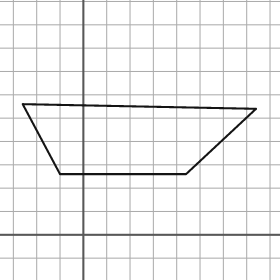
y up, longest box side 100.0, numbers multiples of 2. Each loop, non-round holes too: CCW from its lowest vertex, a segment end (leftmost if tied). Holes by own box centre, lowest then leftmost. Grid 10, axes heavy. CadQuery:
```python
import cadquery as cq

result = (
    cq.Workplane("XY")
    .moveTo(-10.0, 26.0)
    .lineTo(44.0, 26.0)
    .lineTo(74.0, 54.0)
    .lineTo(-26.0, 56.0)
    .close()
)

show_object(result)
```